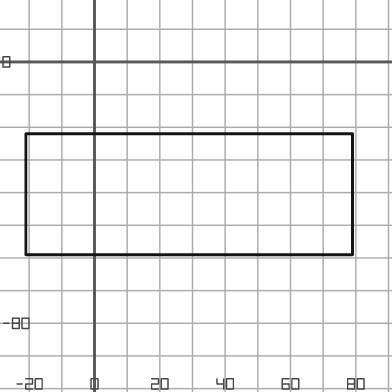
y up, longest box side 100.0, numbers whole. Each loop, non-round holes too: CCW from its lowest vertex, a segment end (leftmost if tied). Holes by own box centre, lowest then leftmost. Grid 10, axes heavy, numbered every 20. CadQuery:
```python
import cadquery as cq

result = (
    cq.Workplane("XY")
    .moveTo(-21.0, -59.0)
    .lineTo(79.0, -59.0)
    .lineTo(79.0, -22.0)
    .lineTo(-21.0, -22.0)
    .close()
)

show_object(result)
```